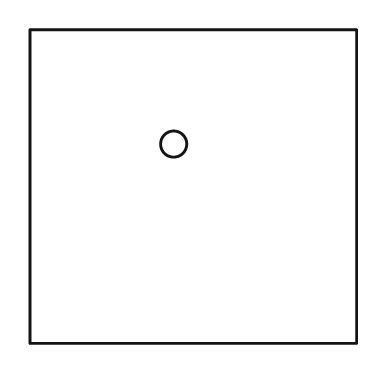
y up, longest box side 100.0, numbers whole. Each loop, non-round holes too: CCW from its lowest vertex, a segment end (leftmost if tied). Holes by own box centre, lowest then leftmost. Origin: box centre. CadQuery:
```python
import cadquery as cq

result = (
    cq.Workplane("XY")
    .moveTo(-50.0, -48.0)
    .lineTo(50.0, -48.0)
    .lineTo(50.0, 48.0)
    .lineTo(-50.0, 48.0)
    .close()
    .moveTo(-6.0, 13.0)
    .circle(4.0)
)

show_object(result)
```